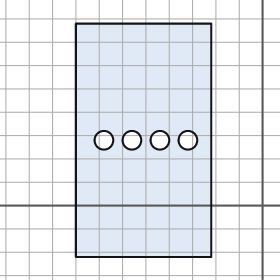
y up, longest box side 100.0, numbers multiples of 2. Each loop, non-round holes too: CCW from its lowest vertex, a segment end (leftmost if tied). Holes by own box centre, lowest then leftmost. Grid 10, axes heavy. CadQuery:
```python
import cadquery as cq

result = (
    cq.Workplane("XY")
    .moveTo(-80.0, -22.0)
    .lineTo(-22.0, -22.0)
    .lineTo(-22.0, 78.0)
    .lineTo(-80.0, 78.0)
    .close()
    .moveTo(-68.0, 28.0)
    .circle(4.0)
    .moveTo(-56.0, 28.0)
    .circle(4.0)
    .moveTo(-44.0, 28.0)
    .circle(4.0)
    .moveTo(-32.0, 28.0)
    .circle(4.0)
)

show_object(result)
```